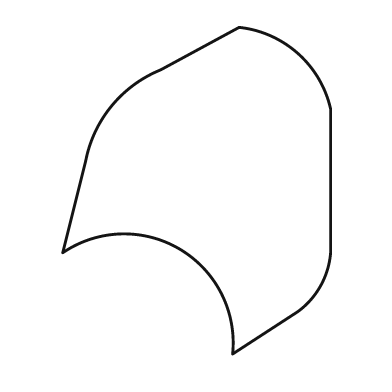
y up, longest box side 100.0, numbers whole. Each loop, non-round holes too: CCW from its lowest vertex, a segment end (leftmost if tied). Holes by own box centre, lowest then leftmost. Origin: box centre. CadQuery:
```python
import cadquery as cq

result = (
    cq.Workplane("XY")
    .moveTo(11.0, -50.0)
    .lineTo(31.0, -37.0)
    .threePointArc((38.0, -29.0), (41.0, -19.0))
    .lineTo(41.0, 25.0)
    .threePointArc((31.0, 42.0), (13.0, 50.0))
    .lineTo(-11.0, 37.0)
    .threePointArc((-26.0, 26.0), (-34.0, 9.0))
    .lineTo(-41.0, -19.0)
    .threePointArc((-5.0, -18.0), (11.0, -50.0))
    .close()
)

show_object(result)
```